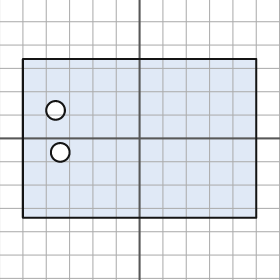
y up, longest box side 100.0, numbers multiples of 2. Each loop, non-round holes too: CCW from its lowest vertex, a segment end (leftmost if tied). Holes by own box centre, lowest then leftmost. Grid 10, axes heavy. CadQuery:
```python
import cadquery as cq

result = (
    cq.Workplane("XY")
    .moveTo(-50.0, -34.0)
    .lineTo(50.0, -34.0)
    .lineTo(50.0, 34.0)
    .lineTo(-50.0, 34.0)
    .close()
    .moveTo(-34.0, -6.0)
    .circle(4.0)
    .moveTo(-36.0, 12.0)
    .circle(4.0)
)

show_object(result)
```